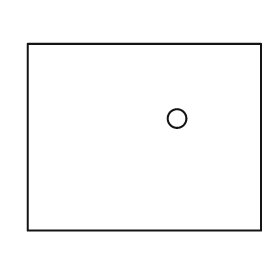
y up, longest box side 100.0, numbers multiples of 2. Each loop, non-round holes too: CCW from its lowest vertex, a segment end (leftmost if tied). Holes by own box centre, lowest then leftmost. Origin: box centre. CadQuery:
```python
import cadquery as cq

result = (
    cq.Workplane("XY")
    .moveTo(-50.0, -40.0)
    .lineTo(50.0, -40.0)
    .lineTo(50.0, 40.0)
    .lineTo(-50.0, 40.0)
    .close()
    .moveTo(14.0, 8.0)
    .circle(4.0)
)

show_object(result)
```